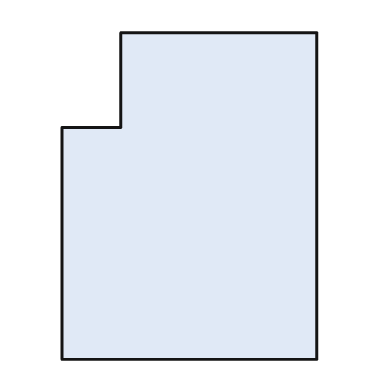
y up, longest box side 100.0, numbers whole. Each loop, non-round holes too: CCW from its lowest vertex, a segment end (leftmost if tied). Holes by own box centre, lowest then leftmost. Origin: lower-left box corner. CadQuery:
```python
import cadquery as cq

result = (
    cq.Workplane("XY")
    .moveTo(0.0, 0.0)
    .lineTo(78.0, 0.0)
    .lineTo(78.0, 100.0)
    .lineTo(18.0, 100.0)
    .lineTo(18.0, 71.0)
    .lineTo(0.0, 71.0)
    .close()
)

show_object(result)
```